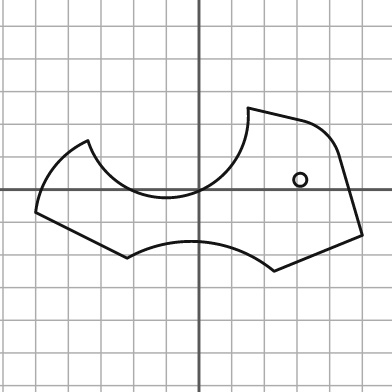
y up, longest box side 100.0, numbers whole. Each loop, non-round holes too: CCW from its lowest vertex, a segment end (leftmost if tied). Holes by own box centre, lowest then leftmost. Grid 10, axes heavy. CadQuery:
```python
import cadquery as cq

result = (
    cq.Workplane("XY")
    .moveTo(23.0, -25.0)
    .lineTo(50.0, -14.0)
    .lineTo(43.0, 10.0)
    .threePointArc((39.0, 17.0), (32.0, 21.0))
    .lineTo(15.0, 25.0)
    .threePointArc((-5.0, -2.0), (-34.0, 15.0))
    .threePointArc((-45.0, 6.0), (-50.0, -7.0))
    .lineTo(-22.0, -21.0)
    .threePointArc((1.0, -16.0), (23.0, -25.0))
    .close()
    .moveTo(31.0, 3.0)
    .circle(2.0)
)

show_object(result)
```